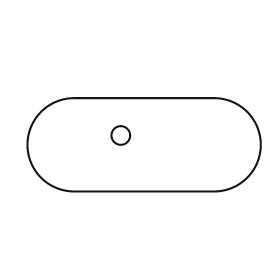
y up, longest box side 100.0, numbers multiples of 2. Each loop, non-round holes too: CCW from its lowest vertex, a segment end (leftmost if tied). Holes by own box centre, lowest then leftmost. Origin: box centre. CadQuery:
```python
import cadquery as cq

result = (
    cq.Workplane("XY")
    .moveTo(-30.0, -20.0)
    .lineTo(30.0, -20.0)
    .threePointArc((50.0, 0.0), (30.0, 20.0))
    .lineTo(-30.0, 20.0)
    .threePointArc((-50.0, 0.0), (-30.0, -20.0))
    .close()
    .moveTo(-10.0, 4.0)
    .circle(4.0)
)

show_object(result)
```